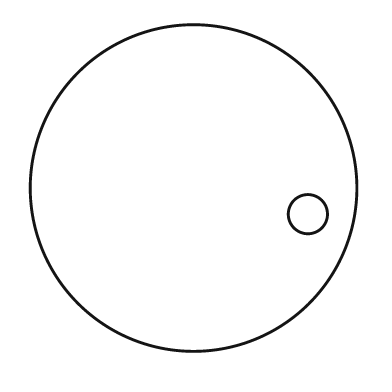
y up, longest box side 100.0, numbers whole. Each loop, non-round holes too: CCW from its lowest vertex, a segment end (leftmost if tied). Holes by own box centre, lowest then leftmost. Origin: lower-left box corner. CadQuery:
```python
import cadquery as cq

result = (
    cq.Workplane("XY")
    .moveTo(50.0, 50.0)
    .circle(50.0)
    .moveTo(85.0, 42.0)
    .circle(6.0)
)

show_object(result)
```